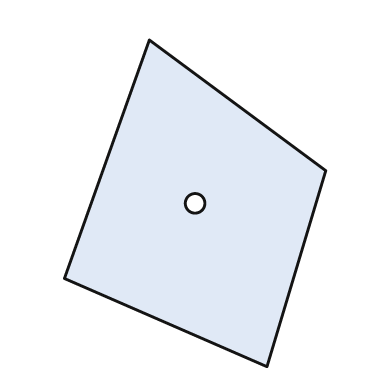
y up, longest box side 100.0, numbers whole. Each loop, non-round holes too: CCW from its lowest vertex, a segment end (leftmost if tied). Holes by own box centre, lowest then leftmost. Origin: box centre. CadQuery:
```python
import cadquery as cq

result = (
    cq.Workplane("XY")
    .moveTo(22.0, -50.0)
    .lineTo(40.0, 10.0)
    .lineTo(-14.0, 50.0)
    .lineTo(-40.0, -23.0)
    .close()
    .moveTo(0.0, 0.0)
    .circle(3.0)
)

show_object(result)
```